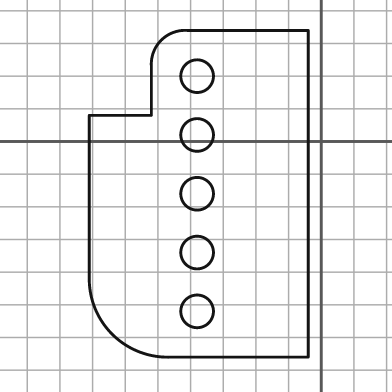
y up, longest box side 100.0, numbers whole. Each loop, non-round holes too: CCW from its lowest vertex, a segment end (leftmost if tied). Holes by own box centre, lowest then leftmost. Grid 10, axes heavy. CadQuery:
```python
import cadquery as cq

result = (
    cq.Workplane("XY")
    .moveTo(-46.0, -66.0)
    .lineTo(-4.0, -66.0)
    .lineTo(-4.0, 34.0)
    .lineTo(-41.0, 34.0)
    .threePointArc((-49.0, 31.0), (-52.0, 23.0))
    .lineTo(-52.0, 8.0)
    .lineTo(-71.0, 8.0)
    .lineTo(-71.0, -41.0)
    .threePointArc((-64.0, -59.0), (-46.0, -66.0))
    .close()
    .moveTo(-38.0, -52.0)
    .circle(5.0)
    .moveTo(-38.0, -34.0)
    .circle(5.0)
    .moveTo(-38.0, -16.0)
    .circle(5.0)
    .moveTo(-38.0, 2.0)
    .circle(5.0)
    .moveTo(-38.0, 20.0)
    .circle(5.0)
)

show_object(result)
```